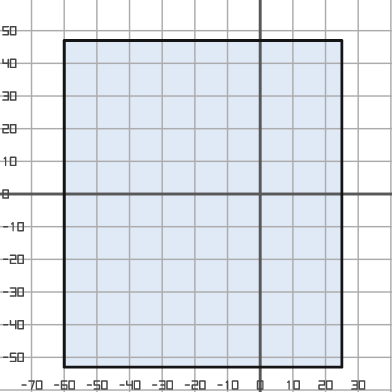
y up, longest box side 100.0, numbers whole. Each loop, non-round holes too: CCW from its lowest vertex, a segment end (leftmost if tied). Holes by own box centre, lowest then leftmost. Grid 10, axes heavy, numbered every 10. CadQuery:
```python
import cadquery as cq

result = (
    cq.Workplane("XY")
    .moveTo(-60.0, -53.0)
    .lineTo(25.0, -53.0)
    .lineTo(25.0, 47.0)
    .lineTo(-60.0, 47.0)
    .close()
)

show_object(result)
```